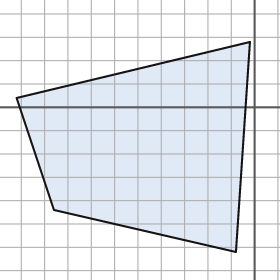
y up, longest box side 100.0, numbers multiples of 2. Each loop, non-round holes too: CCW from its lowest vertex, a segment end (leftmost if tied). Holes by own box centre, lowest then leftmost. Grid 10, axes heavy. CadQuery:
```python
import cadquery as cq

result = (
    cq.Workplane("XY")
    .moveTo(-8.0, -62.0)
    .lineTo(-2.0, 28.0)
    .lineTo(-102.0, 4.0)
    .lineTo(-86.0, -44.0)
    .close()
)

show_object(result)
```